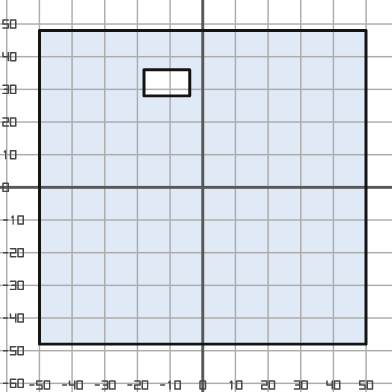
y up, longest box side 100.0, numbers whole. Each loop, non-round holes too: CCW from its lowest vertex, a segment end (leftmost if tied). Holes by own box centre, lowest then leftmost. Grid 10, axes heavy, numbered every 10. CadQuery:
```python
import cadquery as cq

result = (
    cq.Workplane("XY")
    .moveTo(-50.0, -48.0)
    .lineTo(50.0, -48.0)
    .lineTo(50.0, 48.0)
    .lineTo(-50.0, 48.0)
    .close()
    .moveTo(-18.0, 28.0)
    .lineTo(-4.0, 28.0)
    .lineTo(-4.0, 36.0)
    .lineTo(-18.0, 36.0)
    .close()
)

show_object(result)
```